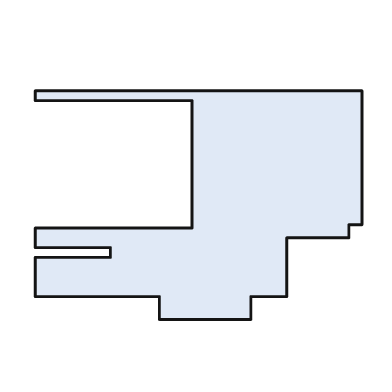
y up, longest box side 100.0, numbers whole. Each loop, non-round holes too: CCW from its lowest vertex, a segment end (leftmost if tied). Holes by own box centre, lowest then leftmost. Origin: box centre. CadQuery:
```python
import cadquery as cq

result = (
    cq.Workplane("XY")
    .moveTo(-12.0, -35.0)
    .lineTo(16.0, -35.0)
    .lineTo(16.0, -28.0)
    .lineTo(27.0, -28.0)
    .lineTo(27.0, -10.0)
    .lineTo(46.0, -10.0)
    .lineTo(46.0, -6.0)
    .lineTo(50.0, -6.0)
    .lineTo(50.0, 35.0)
    .lineTo(-50.0, 35.0)
    .lineTo(-50.0, 32.0)
    .lineTo(-2.0, 32.0)
    .lineTo(-2.0, -7.0)
    .lineTo(-50.0, -7.0)
    .lineTo(-50.0, -13.0)
    .lineTo(-27.0, -13.0)
    .lineTo(-27.0, -16.0)
    .lineTo(-50.0, -16.0)
    .lineTo(-50.0, -28.0)
    .lineTo(-12.0, -28.0)
    .close()
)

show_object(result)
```